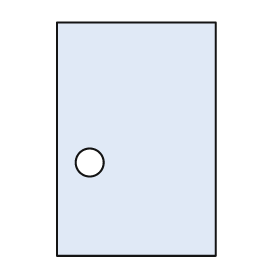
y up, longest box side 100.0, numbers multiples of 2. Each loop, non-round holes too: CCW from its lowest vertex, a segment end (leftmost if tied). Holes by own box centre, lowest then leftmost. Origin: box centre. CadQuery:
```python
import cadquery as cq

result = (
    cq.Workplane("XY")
    .moveTo(-34.0, -50.0)
    .lineTo(34.0, -50.0)
    .lineTo(34.0, 50.0)
    .lineTo(-34.0, 50.0)
    .close()
    .moveTo(-20.0, -10.0)
    .circle(6.0)
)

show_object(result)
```